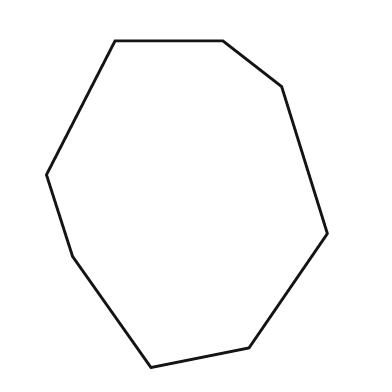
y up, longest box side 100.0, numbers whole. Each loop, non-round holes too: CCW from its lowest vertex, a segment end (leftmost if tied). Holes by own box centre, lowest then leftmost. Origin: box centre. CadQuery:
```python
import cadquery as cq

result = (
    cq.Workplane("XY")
    .moveTo(-11.0, -50.0)
    .lineTo(19.0, -44.0)
    .lineTo(43.0, -9.0)
    .lineTo(29.0, 36.0)
    .lineTo(11.0, 50.0)
    .lineTo(-22.0, 50.0)
    .lineTo(-43.0, 9.0)
    .lineTo(-35.0, -16.0)
    .close()
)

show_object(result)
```